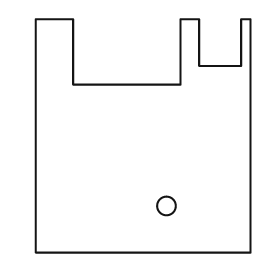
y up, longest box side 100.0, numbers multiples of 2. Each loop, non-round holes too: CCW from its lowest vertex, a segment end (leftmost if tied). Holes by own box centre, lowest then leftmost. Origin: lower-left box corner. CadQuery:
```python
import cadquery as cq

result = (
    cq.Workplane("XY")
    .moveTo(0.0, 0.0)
    .lineTo(92.0, 0.0)
    .lineTo(92.0, 100.0)
    .lineTo(88.0, 100.0)
    .lineTo(88.0, 80.0)
    .lineTo(70.0, 80.0)
    .lineTo(70.0, 100.0)
    .lineTo(62.0, 100.0)
    .lineTo(62.0, 72.0)
    .lineTo(16.0, 72.0)
    .lineTo(16.0, 100.0)
    .lineTo(0.0, 100.0)
    .close()
    .moveTo(56.0, 20.0)
    .circle(4.0)
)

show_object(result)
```